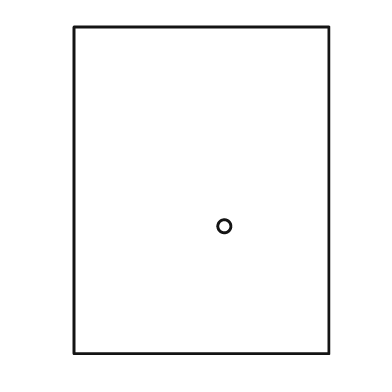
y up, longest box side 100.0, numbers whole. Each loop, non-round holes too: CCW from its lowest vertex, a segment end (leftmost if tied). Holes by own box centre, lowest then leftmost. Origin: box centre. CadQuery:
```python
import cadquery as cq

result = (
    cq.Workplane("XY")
    .moveTo(-39.0, -50.0)
    .lineTo(39.0, -50.0)
    .lineTo(39.0, 50.0)
    .lineTo(-39.0, 50.0)
    .close()
    .moveTo(7.0, -11.0)
    .circle(2.0)
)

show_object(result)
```